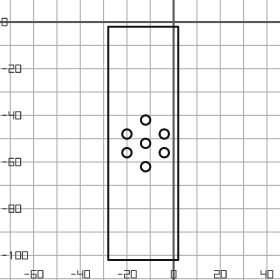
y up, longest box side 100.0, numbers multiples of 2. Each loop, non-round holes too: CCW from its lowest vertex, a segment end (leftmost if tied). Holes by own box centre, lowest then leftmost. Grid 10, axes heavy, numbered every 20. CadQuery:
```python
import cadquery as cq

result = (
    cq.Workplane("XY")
    .moveTo(-28.0, -102.0)
    .lineTo(2.0, -102.0)
    .lineTo(2.0, -2.0)
    .lineTo(-28.0, -2.0)
    .close()
    .moveTo(-12.0, -62.0)
    .circle(2.0)
    .moveTo(-20.0, -56.0)
    .circle(2.0)
    .moveTo(-4.0, -56.0)
    .circle(2.0)
    .moveTo(-12.0, -52.0)
    .circle(2.0)
    .moveTo(-20.0, -48.0)
    .circle(2.0)
    .moveTo(-4.0, -48.0)
    .circle(2.0)
    .moveTo(-12.0, -42.0)
    .circle(2.0)
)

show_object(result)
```